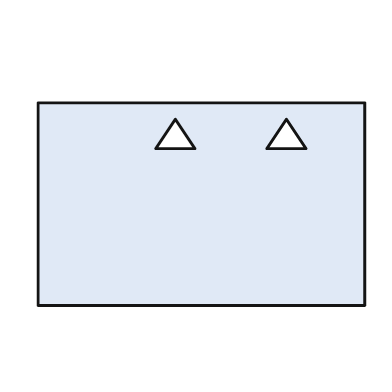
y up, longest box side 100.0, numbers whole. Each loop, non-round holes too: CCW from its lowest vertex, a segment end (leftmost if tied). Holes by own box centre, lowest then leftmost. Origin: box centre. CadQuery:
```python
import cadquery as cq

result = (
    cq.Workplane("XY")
    .moveTo(-50.0, -31.0)
    .lineTo(50.0, -31.0)
    .lineTo(50.0, 31.0)
    .lineTo(-50.0, 31.0)
    .close()
    .moveTo(-14.0, 17.0)
    .lineTo(-2.0, 17.0)
    .lineTo(-8.0, 26.0)
    .close()
    .moveTo(20.0, 17.0)
    .lineTo(32.0, 17.0)
    .lineTo(26.0, 26.0)
    .close()
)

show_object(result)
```